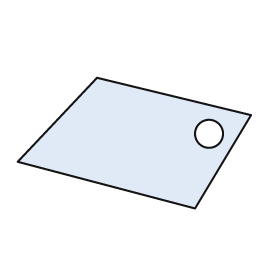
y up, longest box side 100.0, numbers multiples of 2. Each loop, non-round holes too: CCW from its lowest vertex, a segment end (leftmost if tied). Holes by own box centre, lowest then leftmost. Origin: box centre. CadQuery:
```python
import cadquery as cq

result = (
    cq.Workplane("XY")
    .moveTo(26.0, -28.0)
    .lineTo(50.0, 12.0)
    .lineTo(-16.0, 28.0)
    .lineTo(-50.0, -8.0)
    .close()
    .moveTo(32.0, 4.0)
    .circle(6.0)
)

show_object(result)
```